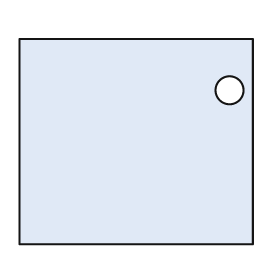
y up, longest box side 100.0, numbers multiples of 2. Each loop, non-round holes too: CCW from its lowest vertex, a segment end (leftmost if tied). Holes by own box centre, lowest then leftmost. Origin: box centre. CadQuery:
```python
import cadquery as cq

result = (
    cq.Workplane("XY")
    .moveTo(-50.0, -44.0)
    .lineTo(50.0, -44.0)
    .lineTo(50.0, 44.0)
    .lineTo(-50.0, 44.0)
    .close()
    .moveTo(40.0, 22.0)
    .circle(6.0)
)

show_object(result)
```